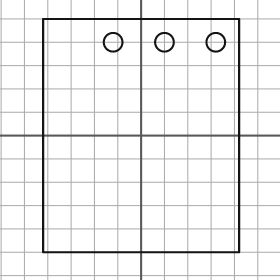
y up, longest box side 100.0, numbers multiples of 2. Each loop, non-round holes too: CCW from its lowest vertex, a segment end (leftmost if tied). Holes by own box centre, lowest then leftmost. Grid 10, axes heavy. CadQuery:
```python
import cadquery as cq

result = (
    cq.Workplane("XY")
    .moveTo(-42.0, -50.0)
    .lineTo(42.0, -50.0)
    .lineTo(42.0, 50.0)
    .lineTo(-42.0, 50.0)
    .close()
    .moveTo(-12.0, 40.0)
    .circle(4.0)
    .moveTo(10.0, 40.0)
    .circle(4.0)
    .moveTo(32.0, 40.0)
    .circle(4.0)
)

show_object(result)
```